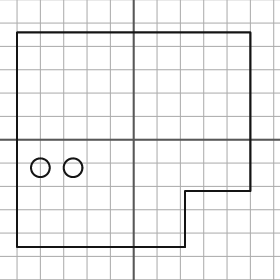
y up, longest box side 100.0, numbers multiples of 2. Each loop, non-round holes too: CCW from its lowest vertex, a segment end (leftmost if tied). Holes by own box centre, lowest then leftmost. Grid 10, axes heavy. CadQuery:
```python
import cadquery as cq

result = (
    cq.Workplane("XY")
    .moveTo(-50.0, -46.0)
    .lineTo(22.0, -46.0)
    .lineTo(22.0, -22.0)
    .lineTo(50.0, -22.0)
    .lineTo(50.0, 46.0)
    .lineTo(-50.0, 46.0)
    .close()
    .moveTo(-40.0, -12.0)
    .circle(4.0)
    .moveTo(-26.0, -12.0)
    .circle(4.0)
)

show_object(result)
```